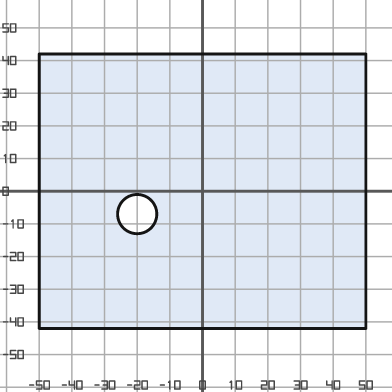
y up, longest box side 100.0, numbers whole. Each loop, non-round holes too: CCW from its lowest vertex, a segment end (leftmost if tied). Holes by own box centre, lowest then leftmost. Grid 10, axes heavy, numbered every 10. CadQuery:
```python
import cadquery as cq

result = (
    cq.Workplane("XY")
    .moveTo(-50.0, -42.0)
    .lineTo(50.0, -42.0)
    .lineTo(50.0, 42.0)
    .lineTo(-50.0, 42.0)
    .close()
    .moveTo(-20.0, -7.0)
    .circle(6.0)
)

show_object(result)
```